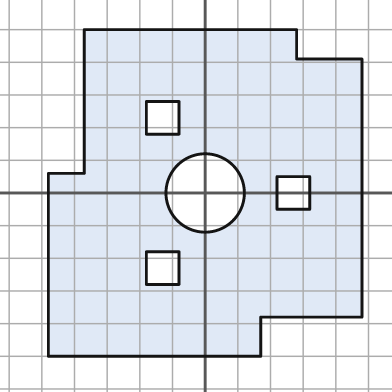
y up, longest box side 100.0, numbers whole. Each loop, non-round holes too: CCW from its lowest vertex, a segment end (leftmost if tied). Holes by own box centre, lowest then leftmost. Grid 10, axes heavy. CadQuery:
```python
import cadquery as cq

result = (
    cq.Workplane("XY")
    .moveTo(-48.0, -50.0)
    .lineTo(17.0, -50.0)
    .lineTo(17.0, -38.0)
    .lineTo(48.0, -38.0)
    .lineTo(48.0, 41.0)
    .lineTo(28.0, 41.0)
    .lineTo(28.0, 50.0)
    .lineTo(-37.0, 50.0)
    .lineTo(-37.0, 6.0)
    .lineTo(-48.0, 6.0)
    .close()
    .moveTo(-18.0, -28.0)
    .lineTo(-8.0, -28.0)
    .lineTo(-8.0, -18.0)
    .lineTo(-18.0, -18.0)
    .close()
    .moveTo(0.0, 0.0)
    .circle(12.0)
    .moveTo(22.0, -5.0)
    .lineTo(32.0, -5.0)
    .lineTo(32.0, 5.0)
    .lineTo(22.0, 5.0)
    .close()
    .moveTo(-18.0, 18.0)
    .lineTo(-8.0, 18.0)
    .lineTo(-8.0, 28.0)
    .lineTo(-18.0, 28.0)
    .close()
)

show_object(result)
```